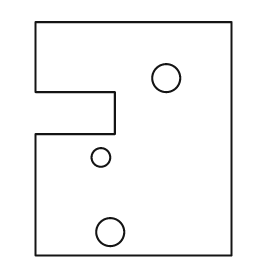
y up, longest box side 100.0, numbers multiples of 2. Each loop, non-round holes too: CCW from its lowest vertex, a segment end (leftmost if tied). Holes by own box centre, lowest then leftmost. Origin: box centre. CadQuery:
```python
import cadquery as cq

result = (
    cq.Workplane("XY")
    .moveTo(-42.0, -50.0)
    .lineTo(42.0, -50.0)
    .lineTo(42.0, 50.0)
    .lineTo(-42.0, 50.0)
    .lineTo(-42.0, 20.0)
    .lineTo(-8.0, 20.0)
    .lineTo(-8.0, 2.0)
    .lineTo(-42.0, 2.0)
    .close()
    .moveTo(-10.0, -40.0)
    .circle(6.0)
    .moveTo(-14.0, -8.0)
    .circle(4.0)
    .moveTo(14.0, 26.0)
    .circle(6.0)
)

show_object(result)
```